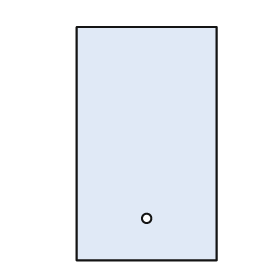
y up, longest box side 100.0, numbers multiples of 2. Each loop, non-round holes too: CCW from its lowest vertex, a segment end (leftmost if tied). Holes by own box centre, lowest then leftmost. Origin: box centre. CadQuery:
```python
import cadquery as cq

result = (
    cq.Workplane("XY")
    .moveTo(-30.0, -50.0)
    .lineTo(30.0, -50.0)
    .lineTo(30.0, 50.0)
    .lineTo(-30.0, 50.0)
    .close()
    .moveTo(0.0, -32.0)
    .circle(2.0)
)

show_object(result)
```